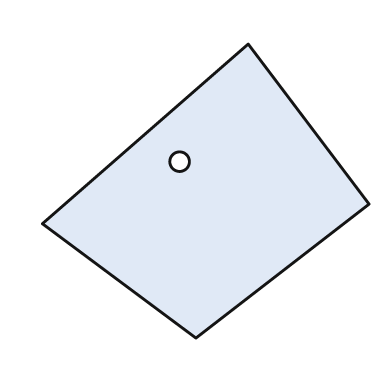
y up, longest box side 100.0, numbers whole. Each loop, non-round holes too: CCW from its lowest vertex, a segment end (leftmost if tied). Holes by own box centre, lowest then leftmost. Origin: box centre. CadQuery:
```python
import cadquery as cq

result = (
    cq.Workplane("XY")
    .moveTo(-3.0, -45.0)
    .lineTo(50.0, -4.0)
    .lineTo(13.0, 45.0)
    .lineTo(-50.0, -10.0)
    .close()
    .moveTo(-8.0, 9.0)
    .circle(3.0)
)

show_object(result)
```